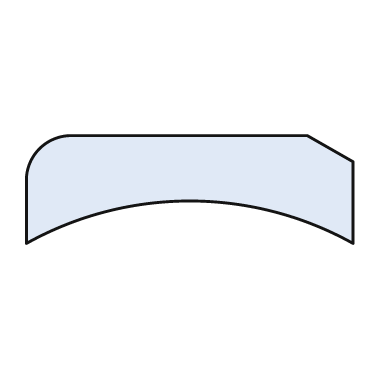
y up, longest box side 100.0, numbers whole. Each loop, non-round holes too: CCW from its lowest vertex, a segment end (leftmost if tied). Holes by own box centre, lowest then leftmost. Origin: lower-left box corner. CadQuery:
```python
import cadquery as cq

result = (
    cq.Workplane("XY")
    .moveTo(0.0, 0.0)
    .threePointArc((50.0, 13.0), (100.0, 0.0))
    .lineTo(100.0, 25.0)
    .lineTo(86.0, 33.0)
    .lineTo(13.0, 33.0)
    .threePointArc((4.0, 29.0), (0.0, 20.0))
    .close()
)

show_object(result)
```